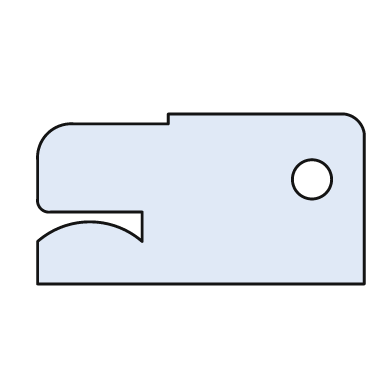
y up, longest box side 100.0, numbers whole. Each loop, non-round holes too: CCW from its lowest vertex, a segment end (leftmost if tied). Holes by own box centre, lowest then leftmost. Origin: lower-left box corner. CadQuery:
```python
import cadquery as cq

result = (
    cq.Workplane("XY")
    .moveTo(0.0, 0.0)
    .lineTo(100.0, 0.0)
    .lineTo(100.0, 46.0)
    .threePointArc((98.0, 50.0), (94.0, 52.0))
    .lineTo(40.0, 52.0)
    .lineTo(40.0, 49.0)
    .lineTo(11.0, 49.0)
    .threePointArc((3.0, 46.0), (0.0, 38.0))
    .lineTo(0.0, 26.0)
    .threePointArc((1.0, 23.0), (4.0, 22.0))
    .lineTo(32.0, 22.0)
    .lineTo(32.0, 13.0)
    .threePointArc((16.0, 19.0), (0.0, 13.0))
    .close()
    .moveTo(84.0, 32.0)
    .circle(6.0)
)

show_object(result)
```